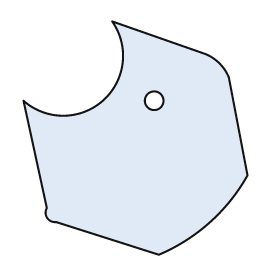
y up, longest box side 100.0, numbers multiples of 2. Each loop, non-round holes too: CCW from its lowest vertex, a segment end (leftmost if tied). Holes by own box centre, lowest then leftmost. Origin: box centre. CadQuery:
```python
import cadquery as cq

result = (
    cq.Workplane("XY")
    .moveTo(10.0, -50.0)
    .threePointArc((32.0, -36.0), (48.0, -16.0))
    .lineTo(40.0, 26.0)
    .threePointArc((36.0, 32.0), (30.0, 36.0))
    .lineTo(-10.0, 50.0)
    .threePointArc((-14.0, 16.0), (-48.0, 16.0))
    .lineTo(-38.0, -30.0)
    .threePointArc((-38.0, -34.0), (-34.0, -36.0))
    .close()
    .moveTo(8.0, 16.0)
    .circle(4.0)
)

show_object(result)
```